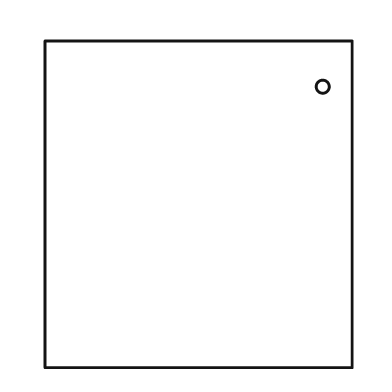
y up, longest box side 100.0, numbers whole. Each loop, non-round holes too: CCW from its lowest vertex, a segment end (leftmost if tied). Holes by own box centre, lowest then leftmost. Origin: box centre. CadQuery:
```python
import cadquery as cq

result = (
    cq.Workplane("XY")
    .moveTo(-47.0, -50.0)
    .lineTo(47.0, -50.0)
    .lineTo(47.0, 50.0)
    .lineTo(-47.0, 50.0)
    .close()
    .moveTo(38.0, 36.0)
    .circle(2.0)
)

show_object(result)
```